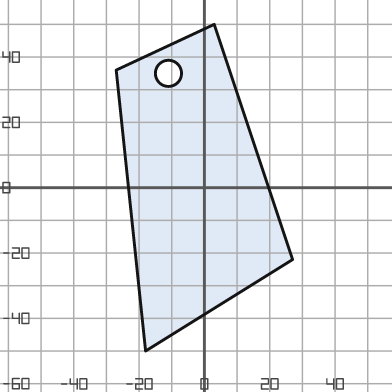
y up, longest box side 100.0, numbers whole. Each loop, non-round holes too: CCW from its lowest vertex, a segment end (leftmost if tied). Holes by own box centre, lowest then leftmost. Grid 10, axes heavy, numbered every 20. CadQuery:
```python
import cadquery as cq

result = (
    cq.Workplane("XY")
    .moveTo(-18.0, -50.0)
    .lineTo(27.0, -22.0)
    .lineTo(3.0, 50.0)
    .lineTo(-27.0, 36.0)
    .close()
    .moveTo(-11.0, 35.0)
    .circle(4.0)
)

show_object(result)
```